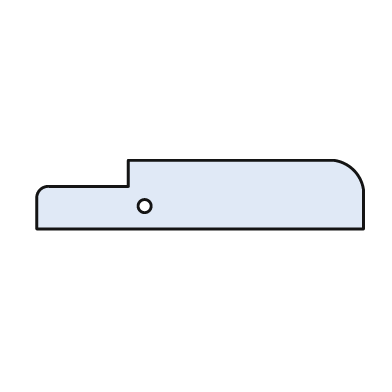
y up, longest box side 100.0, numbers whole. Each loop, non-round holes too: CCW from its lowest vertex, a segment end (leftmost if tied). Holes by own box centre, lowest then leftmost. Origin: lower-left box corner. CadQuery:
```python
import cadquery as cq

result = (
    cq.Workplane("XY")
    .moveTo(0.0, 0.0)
    .lineTo(100.0, 0.0)
    .lineTo(100.0, 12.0)
    .threePointArc((97.0, 18.0), (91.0, 21.0))
    .lineTo(28.0, 21.0)
    .lineTo(28.0, 13.0)
    .lineTo(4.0, 13.0)
    .threePointArc((1.0, 12.0), (0.0, 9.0))
    .close()
    .moveTo(33.0, 7.0)
    .circle(2.0)
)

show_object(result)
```